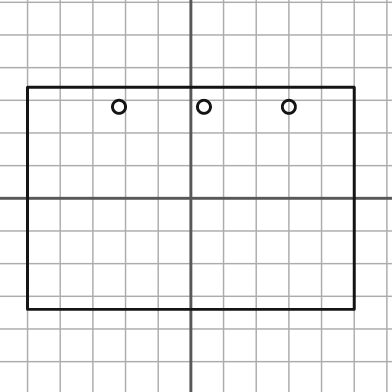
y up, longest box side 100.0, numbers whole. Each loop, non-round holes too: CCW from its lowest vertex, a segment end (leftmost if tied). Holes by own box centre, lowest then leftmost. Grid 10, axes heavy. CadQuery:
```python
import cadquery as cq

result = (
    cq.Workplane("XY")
    .moveTo(-50.0, -34.0)
    .lineTo(50.0, -34.0)
    .lineTo(50.0, 34.0)
    .lineTo(-50.0, 34.0)
    .close()
    .moveTo(-22.0, 28.0)
    .circle(2.0)
    .moveTo(4.0, 28.0)
    .circle(2.0)
    .moveTo(30.0, 28.0)
    .circle(2.0)
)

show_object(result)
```